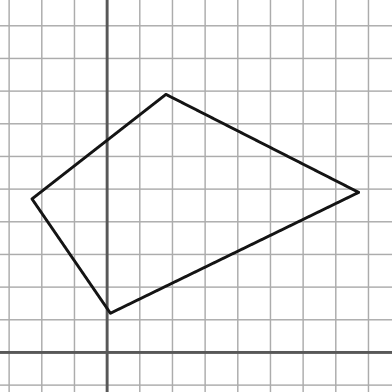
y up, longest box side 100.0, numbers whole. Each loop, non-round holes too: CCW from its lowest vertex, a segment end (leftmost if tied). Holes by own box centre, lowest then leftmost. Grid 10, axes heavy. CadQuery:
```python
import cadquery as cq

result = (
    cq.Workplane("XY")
    .moveTo(1.0, 12.0)
    .lineTo(77.0, 49.0)
    .lineTo(18.0, 79.0)
    .lineTo(-23.0, 47.0)
    .close()
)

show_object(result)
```